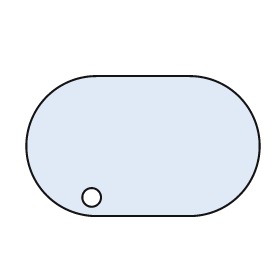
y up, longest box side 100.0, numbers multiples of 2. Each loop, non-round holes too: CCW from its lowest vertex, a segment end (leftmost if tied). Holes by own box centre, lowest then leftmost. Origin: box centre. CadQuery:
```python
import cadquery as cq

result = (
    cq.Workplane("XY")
    .moveTo(-20.0, -30.0)
    .lineTo(20.0, -30.0)
    .threePointArc((50.0, 0.0), (20.0, 30.0))
    .lineTo(-20.0, 30.0)
    .threePointArc((-50.0, 0.0), (-20.0, -30.0))
    .close()
    .moveTo(-22.0, -22.0)
    .circle(4.0)
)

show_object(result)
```